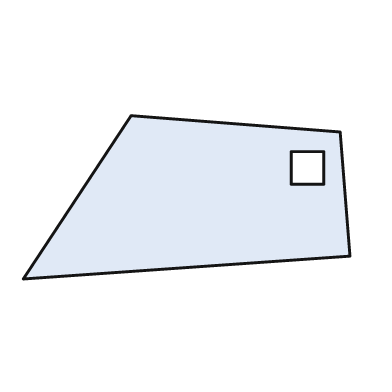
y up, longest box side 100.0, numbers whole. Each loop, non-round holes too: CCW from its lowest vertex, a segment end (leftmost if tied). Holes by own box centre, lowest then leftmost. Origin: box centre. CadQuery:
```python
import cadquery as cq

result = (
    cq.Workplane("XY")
    .moveTo(-50.0, -25.0)
    .lineTo(50.0, -18.0)
    .lineTo(47.0, 20.0)
    .lineTo(-17.0, 25.0)
    .close()
    .moveTo(32.0, 4.0)
    .lineTo(42.0, 4.0)
    .lineTo(42.0, 14.0)
    .lineTo(32.0, 14.0)
    .close()
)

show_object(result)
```